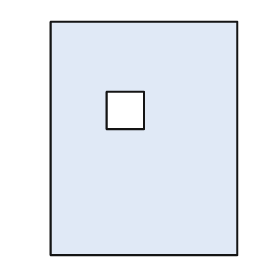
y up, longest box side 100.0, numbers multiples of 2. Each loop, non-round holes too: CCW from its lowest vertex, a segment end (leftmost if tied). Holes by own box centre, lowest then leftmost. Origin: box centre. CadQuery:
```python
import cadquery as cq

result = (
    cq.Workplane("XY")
    .moveTo(-40.0, -50.0)
    .lineTo(40.0, -50.0)
    .lineTo(40.0, 50.0)
    .lineTo(-40.0, 50.0)
    .close()
    .moveTo(-16.0, 4.0)
    .lineTo(0.0, 4.0)
    .lineTo(0.0, 20.0)
    .lineTo(-16.0, 20.0)
    .close()
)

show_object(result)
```